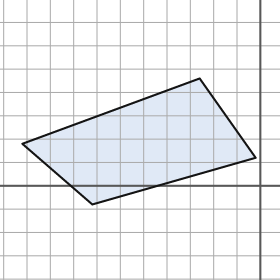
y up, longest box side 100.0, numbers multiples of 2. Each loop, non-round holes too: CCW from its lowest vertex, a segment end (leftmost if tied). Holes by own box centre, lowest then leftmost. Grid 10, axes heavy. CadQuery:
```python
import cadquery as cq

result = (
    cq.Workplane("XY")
    .moveTo(-72.0, -8.0)
    .lineTo(-2.0, 12.0)
    .lineTo(-26.0, 46.0)
    .lineTo(-102.0, 18.0)
    .close()
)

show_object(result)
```